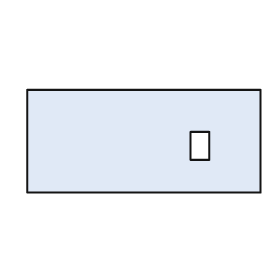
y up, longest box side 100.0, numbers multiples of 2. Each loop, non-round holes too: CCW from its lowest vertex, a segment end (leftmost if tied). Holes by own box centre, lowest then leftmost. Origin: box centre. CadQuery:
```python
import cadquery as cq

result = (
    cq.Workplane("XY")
    .moveTo(-50.0, -22.0)
    .lineTo(50.0, -22.0)
    .lineTo(50.0, 22.0)
    .lineTo(-50.0, 22.0)
    .close()
    .moveTo(20.0, -8.0)
    .lineTo(28.0, -8.0)
    .lineTo(28.0, 4.0)
    .lineTo(20.0, 4.0)
    .close()
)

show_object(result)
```